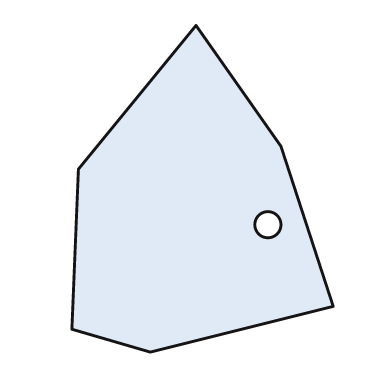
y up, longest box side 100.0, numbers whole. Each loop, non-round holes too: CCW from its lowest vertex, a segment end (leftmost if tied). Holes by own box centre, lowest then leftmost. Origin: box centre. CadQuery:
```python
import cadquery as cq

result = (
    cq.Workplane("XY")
    .moveTo(-16.0, -50.0)
    .lineTo(40.0, -36.0)
    .lineTo(24.0, 13.0)
    .lineTo(-2.0, 50.0)
    .lineTo(-38.0, 6.0)
    .lineTo(-40.0, -43.0)
    .close()
    .moveTo(20.0, -11.0)
    .circle(4.0)
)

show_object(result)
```